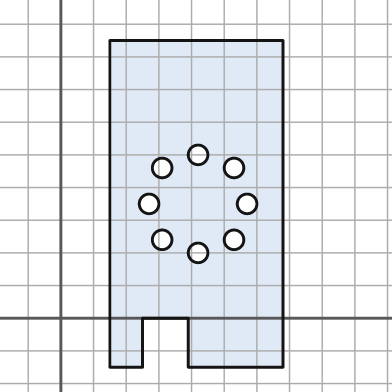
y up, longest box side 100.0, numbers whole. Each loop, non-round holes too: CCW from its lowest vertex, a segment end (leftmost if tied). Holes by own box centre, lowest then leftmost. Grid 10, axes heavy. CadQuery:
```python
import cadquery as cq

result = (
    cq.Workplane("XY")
    .moveTo(15.0, -15.0)
    .lineTo(25.0, -15.0)
    .lineTo(25.0, 0.0)
    .lineTo(39.0, 0.0)
    .lineTo(39.0, -15.0)
    .lineTo(68.0, -15.0)
    .lineTo(68.0, 85.0)
    .lineTo(15.0, 85.0)
    .close()
    .moveTo(42.0, 20.0)
    .circle(3.0)
    .moveTo(31.0, 24.0)
    .circle(3.0)
    .moveTo(53.0, 24.0)
    .circle(3.0)
    .moveTo(27.0, 35.0)
    .circle(3.0)
    .moveTo(57.0, 35.0)
    .circle(3.0)
    .moveTo(31.0, 46.0)
    .circle(3.0)
    .moveTo(53.0, 46.0)
    .circle(3.0)
    .moveTo(42.0, 50.0)
    .circle(3.0)
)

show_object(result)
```